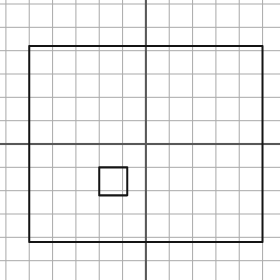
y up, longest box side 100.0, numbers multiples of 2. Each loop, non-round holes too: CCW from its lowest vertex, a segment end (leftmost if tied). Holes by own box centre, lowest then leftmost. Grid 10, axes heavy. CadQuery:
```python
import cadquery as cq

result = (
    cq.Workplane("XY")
    .moveTo(-50.0, -42.0)
    .lineTo(50.0, -42.0)
    .lineTo(50.0, 42.0)
    .lineTo(-50.0, 42.0)
    .close()
    .moveTo(-20.0, -22.0)
    .lineTo(-8.0, -22.0)
    .lineTo(-8.0, -10.0)
    .lineTo(-20.0, -10.0)
    .close()
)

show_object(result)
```